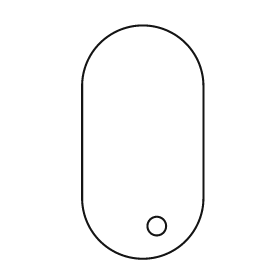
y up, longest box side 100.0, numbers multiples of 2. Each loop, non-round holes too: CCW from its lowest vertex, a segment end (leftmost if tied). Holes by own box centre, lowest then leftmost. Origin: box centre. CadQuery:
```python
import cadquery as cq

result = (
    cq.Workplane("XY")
    .moveTo(-26.0, -24.0)
    .threePointArc((0.0, -50.0), (26.0, -24.0))
    .lineTo(26.0, 24.0)
    .threePointArc((0.0, 50.0), (-26.0, 24.0))
    .close()
    .moveTo(6.0, -36.0)
    .circle(4.0)
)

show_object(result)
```